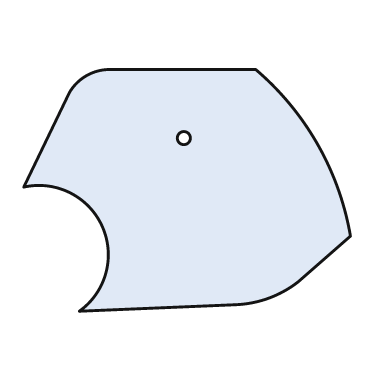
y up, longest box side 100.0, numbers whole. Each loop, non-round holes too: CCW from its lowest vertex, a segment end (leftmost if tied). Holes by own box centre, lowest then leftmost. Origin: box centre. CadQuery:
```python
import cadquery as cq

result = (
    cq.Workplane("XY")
    .moveTo(-33.0, -37.0)
    .lineTo(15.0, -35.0)
    .threePointArc((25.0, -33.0), (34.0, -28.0))
    .lineTo(50.0, -14.0)
    .threePointArc((40.0, 14.0), (21.0, 37.0))
    .lineTo(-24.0, 37.0)
    .threePointArc((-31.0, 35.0), (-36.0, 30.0))
    .lineTo(-50.0, 1.0)
    .threePointArc((-26.0, -11.0), (-33.0, -37.0))
    .close()
    .moveTo(-1.0, 16.0)
    .circle(2.0)
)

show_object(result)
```